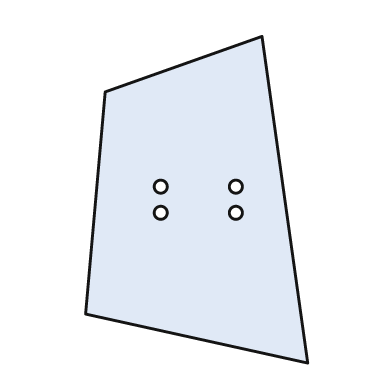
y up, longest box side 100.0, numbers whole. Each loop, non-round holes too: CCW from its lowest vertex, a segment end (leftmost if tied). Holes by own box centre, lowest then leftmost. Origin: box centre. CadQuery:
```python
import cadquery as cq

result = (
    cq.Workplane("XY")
    .moveTo(34.0, -50.0)
    .lineTo(20.0, 50.0)
    .lineTo(-28.0, 33.0)
    .lineTo(-34.0, -35.0)
    .close()
    .moveTo(-11.0, -4.0)
    .circle(2.0)
    .moveTo(12.0, -4.0)
    .circle(2.0)
    .moveTo(-11.0, 4.0)
    .circle(2.0)
    .moveTo(12.0, 4.0)
    .circle(2.0)
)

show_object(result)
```